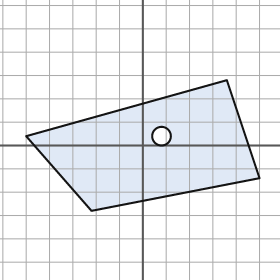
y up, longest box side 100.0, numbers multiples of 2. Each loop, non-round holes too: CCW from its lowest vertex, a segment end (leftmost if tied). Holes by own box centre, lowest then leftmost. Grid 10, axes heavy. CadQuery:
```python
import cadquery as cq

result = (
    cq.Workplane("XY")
    .moveTo(-22.0, -28.0)
    .lineTo(50.0, -14.0)
    .lineTo(36.0, 28.0)
    .lineTo(-50.0, 4.0)
    .close()
    .moveTo(8.0, 4.0)
    .circle(4.0)
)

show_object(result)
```